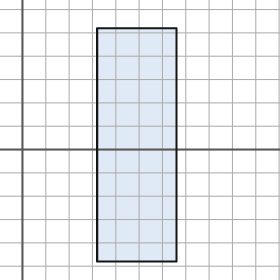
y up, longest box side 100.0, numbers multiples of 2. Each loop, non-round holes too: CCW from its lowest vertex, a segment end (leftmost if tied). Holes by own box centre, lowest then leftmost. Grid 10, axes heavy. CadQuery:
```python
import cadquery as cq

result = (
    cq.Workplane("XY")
    .moveTo(32.0, -48.0)
    .lineTo(66.0, -48.0)
    .lineTo(66.0, 52.0)
    .lineTo(32.0, 52.0)
    .close()
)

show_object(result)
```